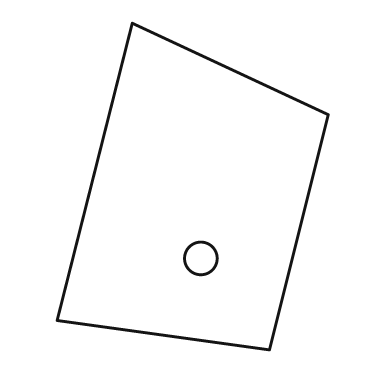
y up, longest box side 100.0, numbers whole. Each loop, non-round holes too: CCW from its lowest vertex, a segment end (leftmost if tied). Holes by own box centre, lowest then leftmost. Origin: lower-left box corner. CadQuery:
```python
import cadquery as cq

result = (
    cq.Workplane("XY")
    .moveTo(65.0, 0.0)
    .lineTo(83.0, 72.0)
    .lineTo(23.0, 100.0)
    .lineTo(0.0, 9.0)
    .close()
    .moveTo(44.0, 28.0)
    .circle(5.0)
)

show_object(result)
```